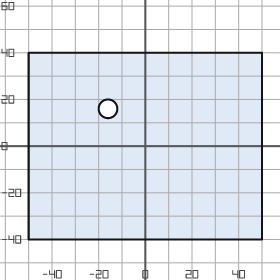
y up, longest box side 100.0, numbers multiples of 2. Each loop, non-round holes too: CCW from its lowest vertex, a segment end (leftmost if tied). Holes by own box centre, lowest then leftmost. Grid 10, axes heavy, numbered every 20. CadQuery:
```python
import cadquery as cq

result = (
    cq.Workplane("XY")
    .moveTo(-50.0, -40.0)
    .lineTo(50.0, -40.0)
    .lineTo(50.0, 40.0)
    .lineTo(-50.0, 40.0)
    .close()
    .moveTo(-16.0, 16.0)
    .circle(4.0)
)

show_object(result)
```